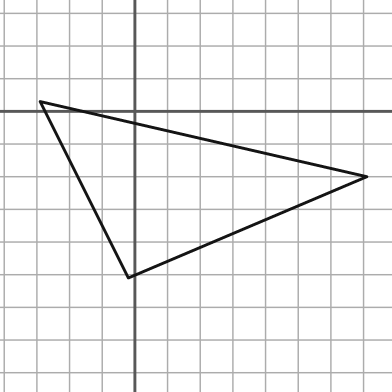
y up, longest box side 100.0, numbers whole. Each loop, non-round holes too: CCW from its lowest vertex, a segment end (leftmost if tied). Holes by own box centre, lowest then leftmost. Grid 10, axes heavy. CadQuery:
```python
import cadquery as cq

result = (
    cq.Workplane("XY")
    .moveTo(-2.0, -51.0)
    .lineTo(71.0, -20.0)
    .lineTo(-29.0, 3.0)
    .close()
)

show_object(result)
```